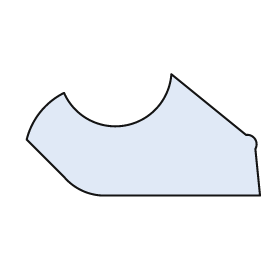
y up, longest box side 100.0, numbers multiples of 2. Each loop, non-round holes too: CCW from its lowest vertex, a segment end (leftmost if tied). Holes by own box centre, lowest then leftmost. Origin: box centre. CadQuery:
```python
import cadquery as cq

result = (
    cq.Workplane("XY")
    .moveTo(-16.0, -26.0)
    .lineTo(50.0, -26.0)
    .lineTo(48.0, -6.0)
    .threePointArc((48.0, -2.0), (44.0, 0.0))
    .lineTo(12.0, 26.0)
    .threePointArc((-8.0, 4.0), (-34.0, 18.0))
    .threePointArc((-44.0, 10.0), (-50.0, -2.0))
    .lineTo(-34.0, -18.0)
    .threePointArc((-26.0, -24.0), (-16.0, -26.0))
    .close()
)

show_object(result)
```